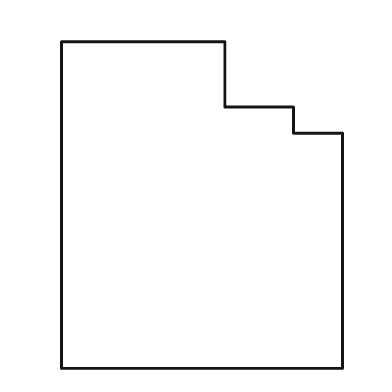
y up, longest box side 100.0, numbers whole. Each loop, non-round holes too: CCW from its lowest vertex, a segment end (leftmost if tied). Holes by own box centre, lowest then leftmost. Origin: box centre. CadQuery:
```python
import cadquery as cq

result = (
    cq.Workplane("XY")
    .moveTo(-43.0, -50.0)
    .lineTo(43.0, -50.0)
    .lineTo(43.0, 22.0)
    .lineTo(28.0, 22.0)
    .lineTo(28.0, 30.0)
    .lineTo(7.0, 30.0)
    .lineTo(7.0, 50.0)
    .lineTo(-43.0, 50.0)
    .close()
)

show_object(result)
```